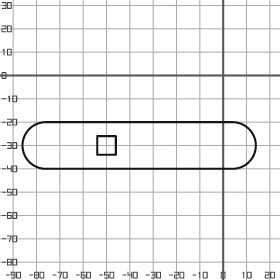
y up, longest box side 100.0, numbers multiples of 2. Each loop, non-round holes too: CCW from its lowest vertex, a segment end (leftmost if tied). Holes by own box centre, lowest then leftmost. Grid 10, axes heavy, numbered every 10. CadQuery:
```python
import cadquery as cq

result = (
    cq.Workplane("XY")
    .moveTo(-76.0, -40.0)
    .lineTo(4.0, -40.0)
    .threePointArc((14.0, -30.0), (4.0, -20.0))
    .lineTo(-76.0, -20.0)
    .threePointArc((-86.0, -30.0), (-76.0, -40.0))
    .close()
    .moveTo(-54.0, -34.0)
    .lineTo(-46.0, -34.0)
    .lineTo(-46.0, -26.0)
    .lineTo(-54.0, -26.0)
    .close()
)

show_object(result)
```